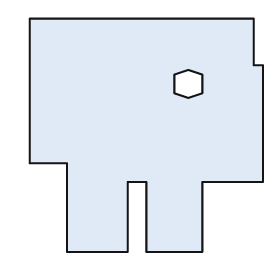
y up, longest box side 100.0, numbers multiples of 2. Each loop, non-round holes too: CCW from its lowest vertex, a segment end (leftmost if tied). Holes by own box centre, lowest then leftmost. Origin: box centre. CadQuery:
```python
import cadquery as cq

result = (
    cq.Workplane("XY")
    .moveTo(-34.0, -50.0)
    .lineTo(-8.0, -50.0)
    .lineTo(-8.0, -20.0)
    .lineTo(0.0, -20.0)
    .lineTo(0.0, -50.0)
    .lineTo(24.0, -50.0)
    .lineTo(24.0, -20.0)
    .lineTo(50.0, -20.0)
    .lineTo(50.0, 30.0)
    .lineTo(46.0, 30.0)
    .lineTo(46.0, 50.0)
    .lineTo(-50.0, 50.0)
    .lineTo(-50.0, -12.0)
    .lineTo(-34.0, -12.0)
    .close()
    .moveTo(18.0, 16.0)
    .lineTo(24.0, 18.0)
    .lineTo(24.0, 26.0)
    .lineTo(18.0, 28.0)
    .lineTo(12.0, 26.0)
    .lineTo(12.0, 18.0)
    .close()
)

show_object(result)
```